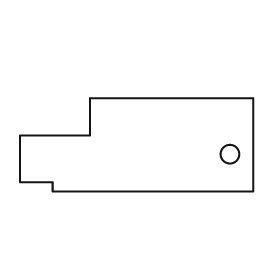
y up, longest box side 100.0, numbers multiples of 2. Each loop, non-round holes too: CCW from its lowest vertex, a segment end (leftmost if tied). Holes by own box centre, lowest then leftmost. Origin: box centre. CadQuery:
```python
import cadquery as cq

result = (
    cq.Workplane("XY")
    .moveTo(-36.0, -20.0)
    .lineTo(50.0, -20.0)
    .lineTo(50.0, 20.0)
    .lineTo(-20.0, 20.0)
    .lineTo(-20.0, 4.0)
    .lineTo(-50.0, 4.0)
    .lineTo(-50.0, -16.0)
    .lineTo(-36.0, -16.0)
    .close()
    .moveTo(40.0, -4.0)
    .circle(4.0)
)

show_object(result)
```